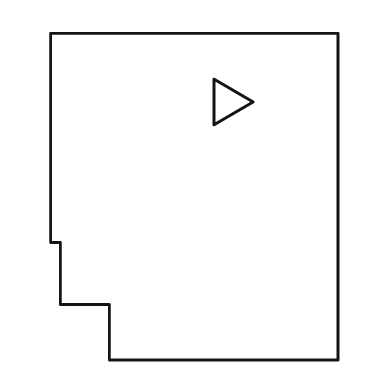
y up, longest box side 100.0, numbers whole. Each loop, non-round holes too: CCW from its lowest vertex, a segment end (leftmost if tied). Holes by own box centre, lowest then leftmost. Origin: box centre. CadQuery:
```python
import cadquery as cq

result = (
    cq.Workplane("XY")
    .moveTo(-26.0, -50.0)
    .lineTo(44.0, -50.0)
    .lineTo(44.0, 50.0)
    .lineTo(-44.0, 50.0)
    .lineTo(-44.0, -14.0)
    .lineTo(-41.0, -14.0)
    .lineTo(-41.0, -33.0)
    .lineTo(-26.0, -33.0)
    .close()
    .moveTo(6.0, 22.0)
    .lineTo(18.0, 29.0)
    .lineTo(6.0, 36.0)
    .close()
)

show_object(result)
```